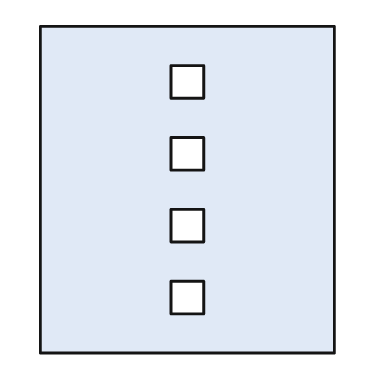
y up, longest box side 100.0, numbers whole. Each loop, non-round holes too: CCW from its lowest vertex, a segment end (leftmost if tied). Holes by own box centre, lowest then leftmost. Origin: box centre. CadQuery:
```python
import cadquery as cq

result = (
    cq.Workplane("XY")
    .moveTo(-45.0, -50.0)
    .lineTo(45.0, -50.0)
    .lineTo(45.0, 50.0)
    .lineTo(-45.0, 50.0)
    .close()
    .moveTo(-5.0, -38.0)
    .lineTo(5.0, -38.0)
    .lineTo(5.0, -28.0)
    .lineTo(-5.0, -28.0)
    .close()
    .moveTo(-5.0, -16.0)
    .lineTo(5.0, -16.0)
    .lineTo(5.0, -6.0)
    .lineTo(-5.0, -6.0)
    .close()
    .moveTo(-5.0, 6.0)
    .lineTo(5.0, 6.0)
    .lineTo(5.0, 16.0)
    .lineTo(-5.0, 16.0)
    .close()
    .moveTo(-5.0, 28.0)
    .lineTo(5.0, 28.0)
    .lineTo(5.0, 38.0)
    .lineTo(-5.0, 38.0)
    .close()
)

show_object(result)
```